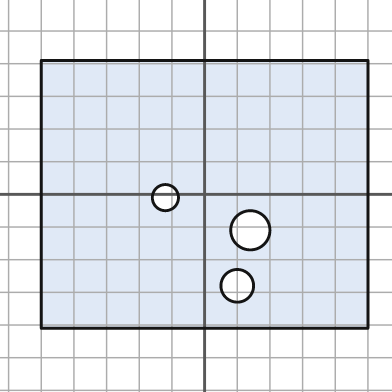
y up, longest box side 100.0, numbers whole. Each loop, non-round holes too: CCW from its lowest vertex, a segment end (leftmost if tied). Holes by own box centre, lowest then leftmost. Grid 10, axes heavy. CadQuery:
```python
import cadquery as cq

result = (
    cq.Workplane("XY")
    .moveTo(-50.0, -41.0)
    .lineTo(50.0, -41.0)
    .lineTo(50.0, 41.0)
    .lineTo(-50.0, 41.0)
    .close()
    .moveTo(10.0, -28.0)
    .circle(5.0)
    .moveTo(14.0, -11.0)
    .circle(6.0)
    .moveTo(-12.0, -1.0)
    .circle(4.0)
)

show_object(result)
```